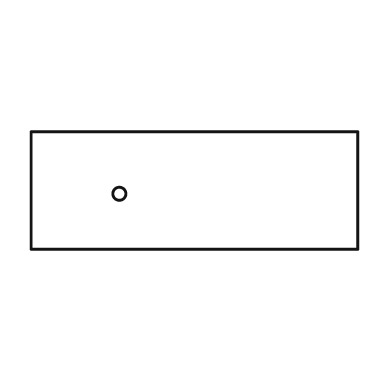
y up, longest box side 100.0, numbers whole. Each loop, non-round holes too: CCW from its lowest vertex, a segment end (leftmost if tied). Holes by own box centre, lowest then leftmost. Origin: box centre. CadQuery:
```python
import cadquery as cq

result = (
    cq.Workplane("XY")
    .moveTo(-50.0, -18.0)
    .lineTo(50.0, -18.0)
    .lineTo(50.0, 18.0)
    .lineTo(-50.0, 18.0)
    .close()
    .moveTo(-23.0, -1.0)
    .circle(2.0)
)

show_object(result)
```